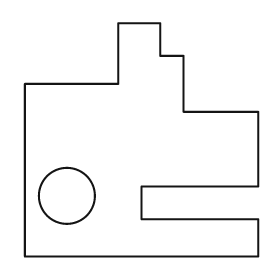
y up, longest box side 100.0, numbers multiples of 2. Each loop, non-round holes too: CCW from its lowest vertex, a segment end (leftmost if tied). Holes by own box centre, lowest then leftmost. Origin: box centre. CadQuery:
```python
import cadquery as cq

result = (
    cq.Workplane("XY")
    .moveTo(-50.0, -50.0)
    .lineTo(50.0, -50.0)
    .lineTo(50.0, -34.0)
    .lineTo(0.0, -34.0)
    .lineTo(0.0, -20.0)
    .lineTo(50.0, -20.0)
    .lineTo(50.0, 12.0)
    .lineTo(18.0, 12.0)
    .lineTo(18.0, 36.0)
    .lineTo(8.0, 36.0)
    .lineTo(8.0, 50.0)
    .lineTo(-10.0, 50.0)
    .lineTo(-10.0, 24.0)
    .lineTo(-50.0, 24.0)
    .close()
    .moveTo(-32.0, -24.0)
    .circle(12.0)
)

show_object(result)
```